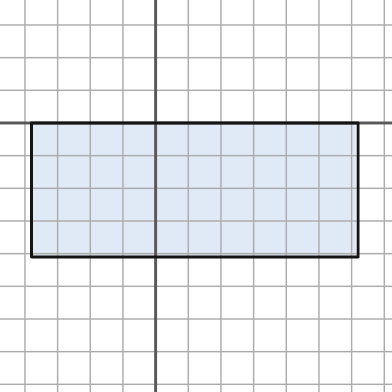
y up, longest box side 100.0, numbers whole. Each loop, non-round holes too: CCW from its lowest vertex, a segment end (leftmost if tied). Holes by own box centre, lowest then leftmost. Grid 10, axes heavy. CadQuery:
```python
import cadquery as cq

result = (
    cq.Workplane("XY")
    .moveTo(-38.0, -41.0)
    .lineTo(62.0, -41.0)
    .lineTo(62.0, 0.0)
    .lineTo(-38.0, 0.0)
    .close()
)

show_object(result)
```